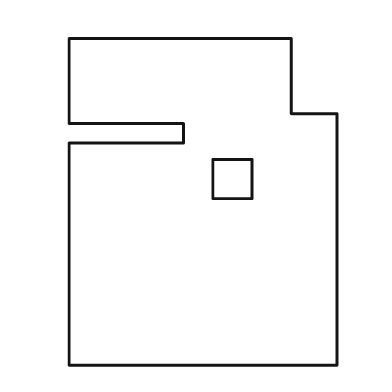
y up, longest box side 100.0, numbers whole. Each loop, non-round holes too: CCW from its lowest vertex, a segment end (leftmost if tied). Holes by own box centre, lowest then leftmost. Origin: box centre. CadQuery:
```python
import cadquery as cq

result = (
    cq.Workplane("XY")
    .moveTo(-41.0, -50.0)
    .lineTo(41.0, -50.0)
    .lineTo(41.0, 27.0)
    .lineTo(27.0, 27.0)
    .lineTo(27.0, 50.0)
    .lineTo(-41.0, 50.0)
    .lineTo(-41.0, 24.0)
    .lineTo(-6.0, 24.0)
    .lineTo(-6.0, 18.0)
    .lineTo(-41.0, 18.0)
    .close()
    .moveTo(3.0, 1.0)
    .lineTo(15.0, 1.0)
    .lineTo(15.0, 13.0)
    .lineTo(3.0, 13.0)
    .close()
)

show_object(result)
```